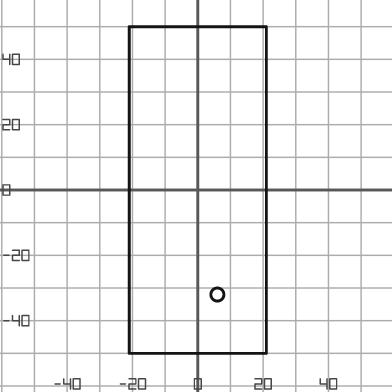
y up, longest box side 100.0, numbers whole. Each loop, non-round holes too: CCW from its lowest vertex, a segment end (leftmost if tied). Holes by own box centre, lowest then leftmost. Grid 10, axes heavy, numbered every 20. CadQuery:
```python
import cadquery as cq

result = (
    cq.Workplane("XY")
    .moveTo(-21.0, -50.0)
    .lineTo(21.0, -50.0)
    .lineTo(21.0, 50.0)
    .lineTo(-21.0, 50.0)
    .close()
    .moveTo(6.0, -32.0)
    .circle(2.0)
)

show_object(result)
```